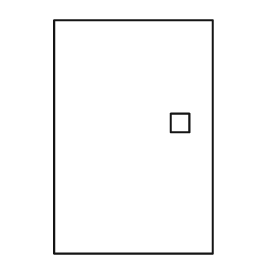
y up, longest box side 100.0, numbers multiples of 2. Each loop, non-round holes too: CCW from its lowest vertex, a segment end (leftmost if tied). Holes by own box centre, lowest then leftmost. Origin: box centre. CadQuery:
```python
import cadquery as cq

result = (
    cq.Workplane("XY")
    .moveTo(-34.0, -50.0)
    .lineTo(34.0, -50.0)
    .lineTo(34.0, 50.0)
    .lineTo(-34.0, 50.0)
    .close()
    .moveTo(16.0, 2.0)
    .lineTo(24.0, 2.0)
    .lineTo(24.0, 10.0)
    .lineTo(16.0, 10.0)
    .close()
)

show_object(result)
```